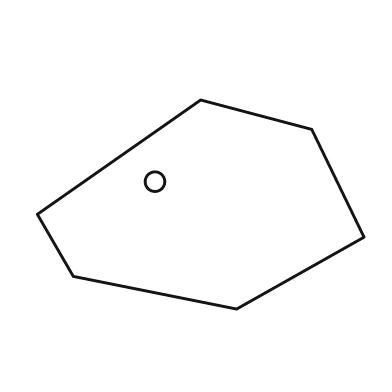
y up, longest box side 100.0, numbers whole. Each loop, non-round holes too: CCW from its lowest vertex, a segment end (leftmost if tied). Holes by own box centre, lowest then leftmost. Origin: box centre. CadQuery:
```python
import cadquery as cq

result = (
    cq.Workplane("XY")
    .moveTo(11.0, -32.0)
    .lineTo(50.0, -10.0)
    .lineTo(34.0, 23.0)
    .lineTo(0.0, 32.0)
    .lineTo(-50.0, -3.0)
    .lineTo(-39.0, -22.0)
    .close()
    .moveTo(-14.0, 7.0)
    .circle(3.0)
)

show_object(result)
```